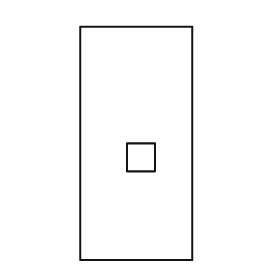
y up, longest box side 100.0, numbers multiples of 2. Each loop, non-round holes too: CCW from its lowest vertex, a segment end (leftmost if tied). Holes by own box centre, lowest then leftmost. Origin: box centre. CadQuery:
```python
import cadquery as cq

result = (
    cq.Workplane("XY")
    .moveTo(-24.0, -50.0)
    .lineTo(24.0, -50.0)
    .lineTo(24.0, 50.0)
    .lineTo(-24.0, 50.0)
    .close()
    .moveTo(-4.0, -12.0)
    .lineTo(8.0, -12.0)
    .lineTo(8.0, 0.0)
    .lineTo(-4.0, 0.0)
    .close()
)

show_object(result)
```